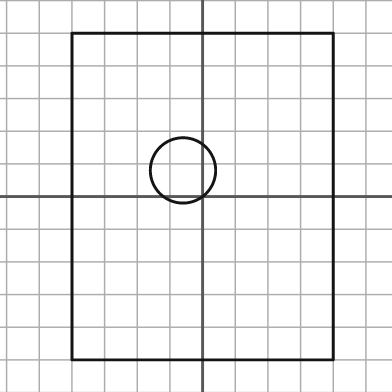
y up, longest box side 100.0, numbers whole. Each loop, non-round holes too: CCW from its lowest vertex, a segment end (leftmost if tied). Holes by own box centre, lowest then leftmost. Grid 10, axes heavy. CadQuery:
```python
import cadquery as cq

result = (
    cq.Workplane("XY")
    .moveTo(-40.0, -50.0)
    .lineTo(40.0, -50.0)
    .lineTo(40.0, 50.0)
    .lineTo(-40.0, 50.0)
    .close()
    .moveTo(-6.0, 8.0)
    .circle(10.0)
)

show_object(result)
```